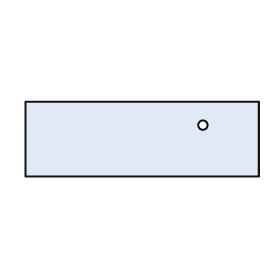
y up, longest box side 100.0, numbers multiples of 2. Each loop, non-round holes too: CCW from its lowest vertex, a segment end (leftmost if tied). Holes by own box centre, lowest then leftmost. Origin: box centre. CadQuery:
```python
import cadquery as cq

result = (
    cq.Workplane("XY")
    .moveTo(-50.0, -16.0)
    .lineTo(50.0, -16.0)
    .lineTo(50.0, 16.0)
    .lineTo(-50.0, 16.0)
    .close()
    .moveTo(26.0, 6.0)
    .circle(2.0)
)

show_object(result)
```